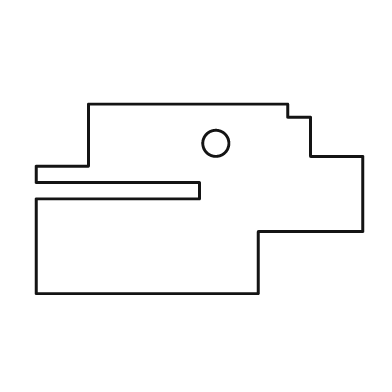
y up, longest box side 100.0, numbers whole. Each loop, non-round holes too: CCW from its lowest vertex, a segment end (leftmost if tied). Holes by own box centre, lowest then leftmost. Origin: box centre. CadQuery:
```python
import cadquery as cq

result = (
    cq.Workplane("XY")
    .moveTo(-50.0, -29.0)
    .lineTo(18.0, -29.0)
    .lineTo(18.0, -10.0)
    .lineTo(50.0, -10.0)
    .lineTo(50.0, 13.0)
    .lineTo(34.0, 13.0)
    .lineTo(34.0, 25.0)
    .lineTo(27.0, 25.0)
    .lineTo(27.0, 29.0)
    .lineTo(-34.0, 29.0)
    .lineTo(-34.0, 10.0)
    .lineTo(-50.0, 10.0)
    .lineTo(-50.0, 5.0)
    .lineTo(0.0, 5.0)
    .lineTo(0.0, 0.0)
    .lineTo(-50.0, 0.0)
    .close()
    .moveTo(5.0, 17.0)
    .circle(4.0)
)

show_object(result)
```